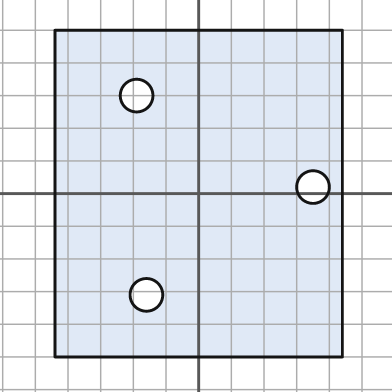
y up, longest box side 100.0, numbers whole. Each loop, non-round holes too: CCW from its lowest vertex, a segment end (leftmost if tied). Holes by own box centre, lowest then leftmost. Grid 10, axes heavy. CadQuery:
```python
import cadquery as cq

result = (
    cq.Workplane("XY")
    .moveTo(-44.0, -50.0)
    .lineTo(44.0, -50.0)
    .lineTo(44.0, 50.0)
    .lineTo(-44.0, 50.0)
    .close()
    .moveTo(-16.0, -31.0)
    .circle(5.0)
    .moveTo(35.0, 2.0)
    .circle(5.0)
    .moveTo(-19.0, 30.0)
    .circle(5.0)
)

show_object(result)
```